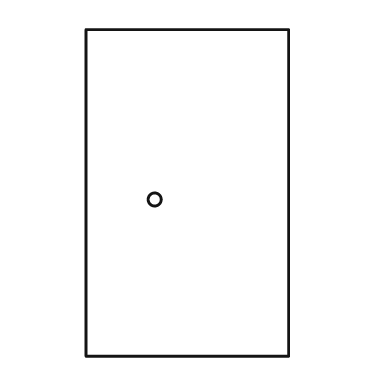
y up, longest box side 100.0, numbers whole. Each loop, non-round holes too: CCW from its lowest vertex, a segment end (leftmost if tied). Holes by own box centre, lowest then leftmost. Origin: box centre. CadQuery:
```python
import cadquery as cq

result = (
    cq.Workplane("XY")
    .moveTo(-31.0, -50.0)
    .lineTo(31.0, -50.0)
    .lineTo(31.0, 50.0)
    .lineTo(-31.0, 50.0)
    .close()
    .moveTo(-10.0, -2.0)
    .circle(2.0)
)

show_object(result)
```